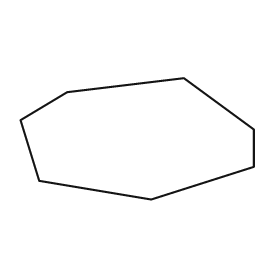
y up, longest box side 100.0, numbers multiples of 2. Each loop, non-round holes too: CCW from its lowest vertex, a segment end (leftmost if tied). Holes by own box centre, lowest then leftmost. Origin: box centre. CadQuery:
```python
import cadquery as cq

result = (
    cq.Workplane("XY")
    .moveTo(6.0, -26.0)
    .lineTo(50.0, -12.0)
    .lineTo(50.0, 4.0)
    .lineTo(20.0, 26.0)
    .lineTo(-30.0, 20.0)
    .lineTo(-50.0, 8.0)
    .lineTo(-42.0, -18.0)
    .close()
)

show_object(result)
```